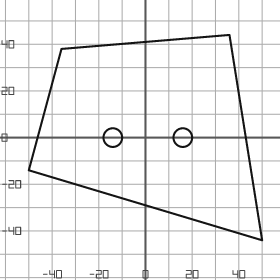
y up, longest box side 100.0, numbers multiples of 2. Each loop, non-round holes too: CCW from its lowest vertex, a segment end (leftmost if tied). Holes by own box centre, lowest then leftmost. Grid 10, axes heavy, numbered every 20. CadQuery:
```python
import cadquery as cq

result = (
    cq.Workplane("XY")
    .moveTo(50.0, -44.0)
    .lineTo(36.0, 44.0)
    .lineTo(-36.0, 38.0)
    .lineTo(-50.0, -14.0)
    .close()
    .moveTo(-14.0, 0.0)
    .circle(4.0)
    .moveTo(16.0, 0.0)
    .circle(4.0)
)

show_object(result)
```